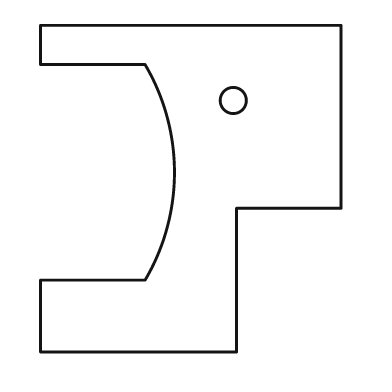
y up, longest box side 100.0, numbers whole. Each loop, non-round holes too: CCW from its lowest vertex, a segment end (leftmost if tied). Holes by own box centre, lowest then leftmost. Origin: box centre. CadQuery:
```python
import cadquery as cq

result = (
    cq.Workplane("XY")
    .moveTo(-46.0, -50.0)
    .lineTo(14.0, -50.0)
    .lineTo(14.0, -6.0)
    .lineTo(46.0, -6.0)
    .lineTo(46.0, 50.0)
    .lineTo(-46.0, 50.0)
    .lineTo(-46.0, 38.0)
    .lineTo(-14.0, 38.0)
    .threePointArc((-5.0, 5.0), (-14.0, -28.0))
    .lineTo(-46.0, -28.0)
    .close()
    .moveTo(13.0, 27.0)
    .circle(4.0)
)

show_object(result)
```